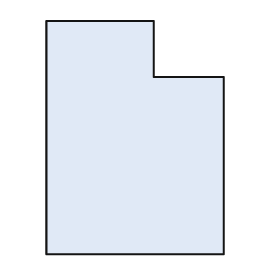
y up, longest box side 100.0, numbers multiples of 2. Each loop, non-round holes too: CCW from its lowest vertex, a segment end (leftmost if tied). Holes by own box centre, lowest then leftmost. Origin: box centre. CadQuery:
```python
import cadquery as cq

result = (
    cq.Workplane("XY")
    .moveTo(-38.0, -50.0)
    .lineTo(38.0, -50.0)
    .lineTo(38.0, 26.0)
    .lineTo(8.0, 26.0)
    .lineTo(8.0, 50.0)
    .lineTo(-38.0, 50.0)
    .close()
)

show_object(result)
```